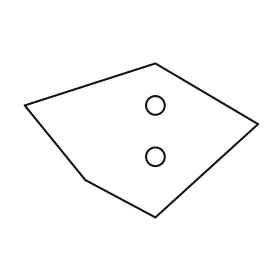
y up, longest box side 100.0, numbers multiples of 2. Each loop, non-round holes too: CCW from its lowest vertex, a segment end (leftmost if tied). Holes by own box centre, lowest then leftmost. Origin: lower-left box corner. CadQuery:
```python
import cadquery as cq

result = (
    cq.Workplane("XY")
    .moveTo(56.0, 0.0)
    .lineTo(100.0, 40.0)
    .lineTo(56.0, 66.0)
    .lineTo(0.0, 48.0)
    .lineTo(26.0, 16.0)
    .close()
    .moveTo(56.0, 26.0)
    .circle(4.0)
    .moveTo(56.0, 48.0)
    .circle(4.0)
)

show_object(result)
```